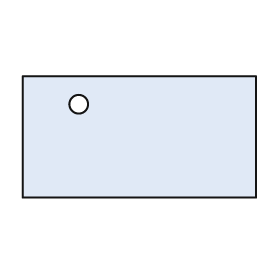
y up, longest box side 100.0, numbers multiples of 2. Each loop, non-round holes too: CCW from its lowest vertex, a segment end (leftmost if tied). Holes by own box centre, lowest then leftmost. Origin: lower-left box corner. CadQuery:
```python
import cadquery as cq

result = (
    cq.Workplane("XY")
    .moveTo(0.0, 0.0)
    .lineTo(100.0, 0.0)
    .lineTo(100.0, 52.0)
    .lineTo(0.0, 52.0)
    .close()
    .moveTo(24.0, 40.0)
    .circle(4.0)
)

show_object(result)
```